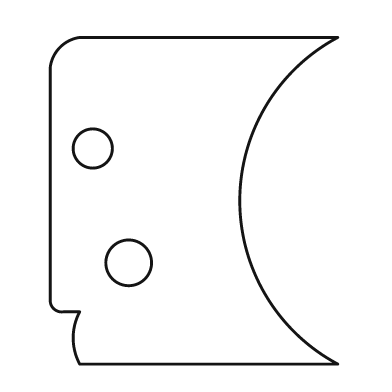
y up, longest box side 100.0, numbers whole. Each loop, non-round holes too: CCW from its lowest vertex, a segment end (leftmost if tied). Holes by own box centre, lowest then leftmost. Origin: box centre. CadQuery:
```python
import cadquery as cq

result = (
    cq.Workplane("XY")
    .moveTo(-35.0, -50.0)
    .lineTo(44.0, -50.0)
    .threePointArc((14.0, 0.0), (44.0, 50.0))
    .lineTo(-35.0, 50.0)
    .threePointArc((-41.0, 47.0), (-44.0, 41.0))
    .lineTo(-44.0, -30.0)
    .threePointArc((-43.0, -33.0), (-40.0, -34.0))
    .lineTo(-35.0, -34.0)
    .threePointArc((-37.0, -42.0), (-35.0, -50.0))
    .close()
    .moveTo(-20.0, -19.0)
    .circle(7.0)
    .moveTo(-31.0, 16.0)
    .circle(6.0)
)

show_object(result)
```